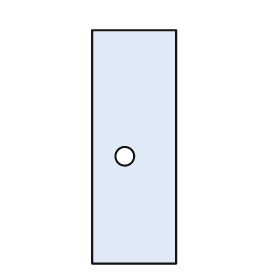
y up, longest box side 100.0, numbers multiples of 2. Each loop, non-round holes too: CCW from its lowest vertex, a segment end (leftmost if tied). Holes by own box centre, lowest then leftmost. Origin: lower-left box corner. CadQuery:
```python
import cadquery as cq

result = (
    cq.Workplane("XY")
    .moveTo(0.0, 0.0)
    .lineTo(36.0, 0.0)
    .lineTo(36.0, 100.0)
    .lineTo(0.0, 100.0)
    .close()
    .moveTo(14.0, 46.0)
    .circle(4.0)
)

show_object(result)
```